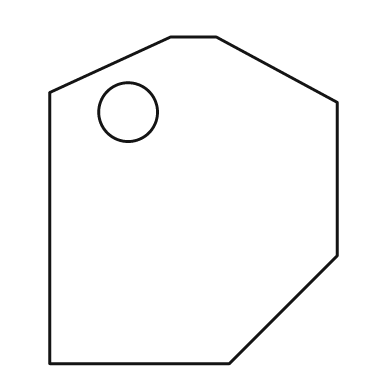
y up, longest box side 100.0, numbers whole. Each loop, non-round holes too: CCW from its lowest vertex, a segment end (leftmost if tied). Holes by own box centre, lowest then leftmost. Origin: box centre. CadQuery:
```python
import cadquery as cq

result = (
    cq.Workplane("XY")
    .moveTo(-44.0, -50.0)
    .lineTo(11.0, -50.0)
    .lineTo(44.0, -17.0)
    .lineTo(44.0, 30.0)
    .lineTo(7.0, 50.0)
    .lineTo(-7.0, 50.0)
    .lineTo(-44.0, 33.0)
    .close()
    .moveTo(-20.0, 27.0)
    .circle(9.0)
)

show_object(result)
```